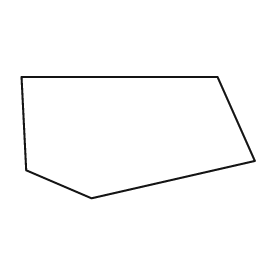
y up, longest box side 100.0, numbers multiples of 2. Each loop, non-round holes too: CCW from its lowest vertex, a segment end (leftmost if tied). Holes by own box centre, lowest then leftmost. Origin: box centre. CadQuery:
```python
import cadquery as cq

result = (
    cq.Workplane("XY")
    .moveTo(-20.0, -26.0)
    .lineTo(50.0, -10.0)
    .lineTo(34.0, 26.0)
    .lineTo(-50.0, 26.0)
    .lineTo(-48.0, -14.0)
    .close()
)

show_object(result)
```